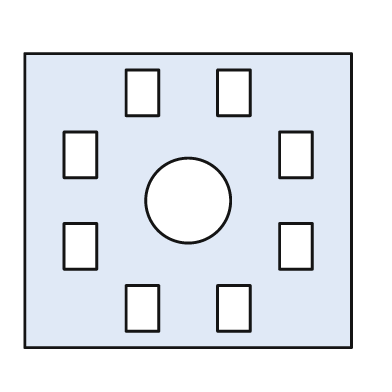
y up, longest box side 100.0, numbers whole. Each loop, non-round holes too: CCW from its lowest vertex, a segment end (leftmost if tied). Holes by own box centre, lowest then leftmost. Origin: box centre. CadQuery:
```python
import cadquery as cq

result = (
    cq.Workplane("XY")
    .moveTo(-50.0, -45.0)
    .lineTo(50.0, -45.0)
    .lineTo(50.0, 45.0)
    .lineTo(-50.0, 45.0)
    .close()
    .moveTo(-19.0, -40.0)
    .lineTo(-9.0, -40.0)
    .lineTo(-9.0, -26.0)
    .lineTo(-19.0, -26.0)
    .close()
    .moveTo(9.0, -40.0)
    .lineTo(19.0, -40.0)
    .lineTo(19.0, -26.0)
    .lineTo(9.0, -26.0)
    .close()
    .moveTo(-38.0, -21.0)
    .lineTo(-28.0, -21.0)
    .lineTo(-28.0, -7.0)
    .lineTo(-38.0, -7.0)
    .close()
    .moveTo(28.0, -21.0)
    .lineTo(38.0, -21.0)
    .lineTo(38.0, -7.0)
    .lineTo(28.0, -7.0)
    .close()
    .moveTo(0.0, 0.0)
    .circle(13.0)
    .moveTo(-38.0, 7.0)
    .lineTo(-28.0, 7.0)
    .lineTo(-28.0, 21.0)
    .lineTo(-38.0, 21.0)
    .close()
    .moveTo(28.0, 7.0)
    .lineTo(38.0, 7.0)
    .lineTo(38.0, 21.0)
    .lineTo(28.0, 21.0)
    .close()
    .moveTo(-19.0, 26.0)
    .lineTo(-9.0, 26.0)
    .lineTo(-9.0, 40.0)
    .lineTo(-19.0, 40.0)
    .close()
    .moveTo(9.0, 26.0)
    .lineTo(19.0, 26.0)
    .lineTo(19.0, 40.0)
    .lineTo(9.0, 40.0)
    .close()
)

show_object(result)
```